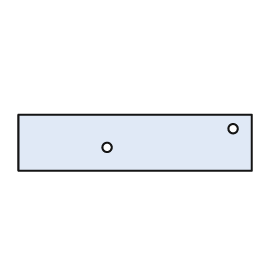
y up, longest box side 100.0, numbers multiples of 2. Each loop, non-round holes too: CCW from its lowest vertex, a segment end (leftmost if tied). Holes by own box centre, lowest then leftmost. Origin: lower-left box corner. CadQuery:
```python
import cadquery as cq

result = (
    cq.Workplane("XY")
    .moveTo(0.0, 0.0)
    .lineTo(100.0, 0.0)
    .lineTo(100.0, 24.0)
    .lineTo(0.0, 24.0)
    .close()
    .moveTo(38.0, 10.0)
    .circle(2.0)
    .moveTo(92.0, 18.0)
    .circle(2.0)
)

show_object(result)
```